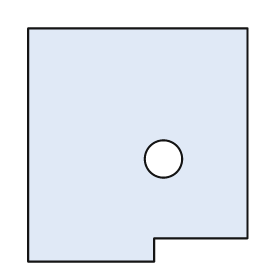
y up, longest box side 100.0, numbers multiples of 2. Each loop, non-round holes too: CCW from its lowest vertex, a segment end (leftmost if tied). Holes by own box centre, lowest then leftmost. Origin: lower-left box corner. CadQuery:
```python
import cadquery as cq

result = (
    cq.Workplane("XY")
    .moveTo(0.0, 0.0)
    .lineTo(54.0, 0.0)
    .lineTo(54.0, 10.0)
    .lineTo(94.0, 10.0)
    .lineTo(94.0, 100.0)
    .lineTo(0.0, 100.0)
    .close()
    .moveTo(58.0, 44.0)
    .circle(8.0)
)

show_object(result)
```